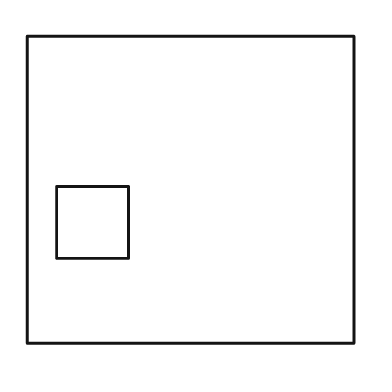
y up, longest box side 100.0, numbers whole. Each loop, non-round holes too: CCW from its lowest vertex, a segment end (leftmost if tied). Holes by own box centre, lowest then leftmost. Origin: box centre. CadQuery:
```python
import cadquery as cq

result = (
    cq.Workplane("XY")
    .moveTo(-50.0, -47.0)
    .lineTo(50.0, -47.0)
    .lineTo(50.0, 47.0)
    .lineTo(-50.0, 47.0)
    .close()
    .moveTo(-41.0, -21.0)
    .lineTo(-19.0, -21.0)
    .lineTo(-19.0, 1.0)
    .lineTo(-41.0, 1.0)
    .close()
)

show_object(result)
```